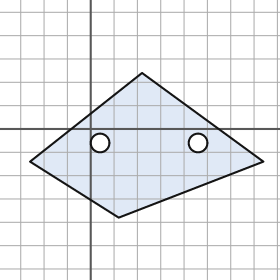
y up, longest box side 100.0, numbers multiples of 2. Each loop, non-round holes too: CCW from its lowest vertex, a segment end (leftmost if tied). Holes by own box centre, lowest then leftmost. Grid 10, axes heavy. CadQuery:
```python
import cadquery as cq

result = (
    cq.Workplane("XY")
    .moveTo(12.0, -38.0)
    .lineTo(74.0, -14.0)
    .lineTo(22.0, 24.0)
    .lineTo(-26.0, -14.0)
    .close()
    .moveTo(4.0, -6.0)
    .circle(4.0)
    .moveTo(46.0, -6.0)
    .circle(4.0)
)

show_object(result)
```